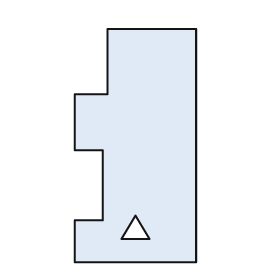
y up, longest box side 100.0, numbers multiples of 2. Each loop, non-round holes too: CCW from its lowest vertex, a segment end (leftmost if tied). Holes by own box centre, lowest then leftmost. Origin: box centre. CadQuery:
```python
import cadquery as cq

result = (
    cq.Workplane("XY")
    .moveTo(-26.0, -50.0)
    .lineTo(26.0, -50.0)
    .lineTo(26.0, 50.0)
    .lineTo(-12.0, 50.0)
    .lineTo(-12.0, 22.0)
    .lineTo(-26.0, 22.0)
    .lineTo(-26.0, -2.0)
    .lineTo(-14.0, -2.0)
    .lineTo(-14.0, -32.0)
    .lineTo(-26.0, -32.0)
    .close()
    .moveTo(-6.0, -40.0)
    .lineTo(6.0, -40.0)
    .lineTo(0.0, -30.0)
    .close()
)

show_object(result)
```